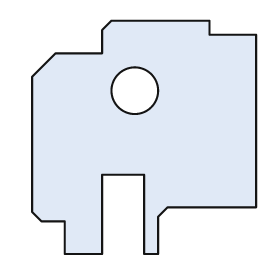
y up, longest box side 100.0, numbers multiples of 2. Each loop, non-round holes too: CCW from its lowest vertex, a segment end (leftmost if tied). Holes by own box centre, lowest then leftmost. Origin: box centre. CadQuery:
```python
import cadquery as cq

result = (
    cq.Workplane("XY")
    .moveTo(-34.0, -50.0)
    .lineTo(-18.0, -50.0)
    .lineTo(-18.0, -16.0)
    .lineTo(0.0, -16.0)
    .lineTo(0.0, -50.0)
    .lineTo(6.0, -50.0)
    .lineTo(6.0, -34.0)
    .lineTo(10.0, -30.0)
    .lineTo(48.0, -30.0)
    .lineTo(48.0, 44.0)
    .lineTo(28.0, 44.0)
    .lineTo(28.0, 50.0)
    .lineTo(-14.0, 50.0)
    .lineTo(-18.0, 46.0)
    .lineTo(-18.0, 36.0)
    .lineTo(-38.0, 36.0)
    .lineTo(-48.0, 26.0)
    .lineTo(-48.0, -32.0)
    .lineTo(-44.0, -36.0)
    .lineTo(-34.0, -36.0)
    .close()
    .moveTo(-4.0, 20.0)
    .circle(10.0)
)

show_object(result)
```